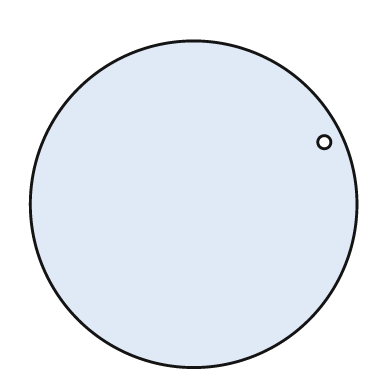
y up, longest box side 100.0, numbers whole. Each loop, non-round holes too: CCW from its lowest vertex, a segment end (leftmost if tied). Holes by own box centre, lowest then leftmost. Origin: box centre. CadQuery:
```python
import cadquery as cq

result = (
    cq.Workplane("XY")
    .moveTo(0.0, 0.0)
    .circle(50.0)
    .moveTo(40.0, 19.0)
    .circle(2.0)
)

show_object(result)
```